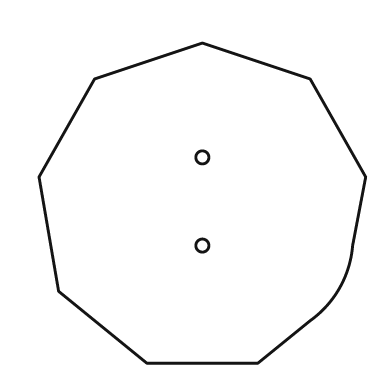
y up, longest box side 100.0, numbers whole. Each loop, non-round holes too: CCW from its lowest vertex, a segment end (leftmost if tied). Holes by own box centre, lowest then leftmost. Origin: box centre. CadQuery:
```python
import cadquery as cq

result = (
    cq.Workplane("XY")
    .moveTo(-17.0, -49.0)
    .lineTo(17.0, -49.0)
    .lineTo(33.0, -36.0)
    .threePointArc((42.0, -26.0), (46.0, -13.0))
    .lineTo(50.0, 8.0)
    .lineTo(33.0, 38.0)
    .lineTo(0.0, 49.0)
    .lineTo(-33.0, 38.0)
    .lineTo(-50.0, 8.0)
    .lineTo(-44.0, -27.0)
    .close()
    .moveTo(0.0, -13.0)
    .circle(2.0)
    .moveTo(0.0, 14.0)
    .circle(2.0)
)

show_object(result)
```